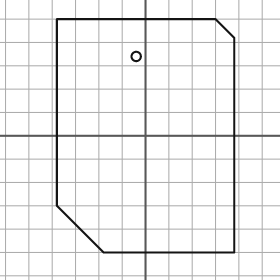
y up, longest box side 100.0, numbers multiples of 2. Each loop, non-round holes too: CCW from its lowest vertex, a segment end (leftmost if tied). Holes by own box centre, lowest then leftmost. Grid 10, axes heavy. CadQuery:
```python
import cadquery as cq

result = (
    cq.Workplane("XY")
    .moveTo(-18.0, -50.0)
    .lineTo(38.0, -50.0)
    .lineTo(38.0, 42.0)
    .lineTo(30.0, 50.0)
    .lineTo(-38.0, 50.0)
    .lineTo(-38.0, -30.0)
    .close()
    .moveTo(-4.0, 34.0)
    .circle(2.0)
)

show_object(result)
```